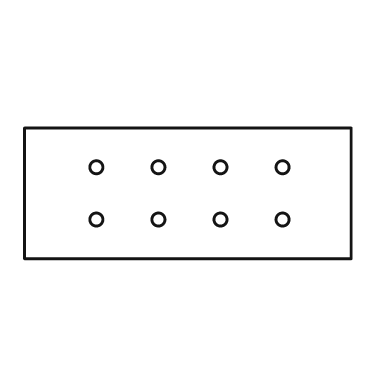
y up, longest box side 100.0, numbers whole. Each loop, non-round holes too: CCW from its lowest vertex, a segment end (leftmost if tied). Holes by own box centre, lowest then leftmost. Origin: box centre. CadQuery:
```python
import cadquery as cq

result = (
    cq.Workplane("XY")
    .moveTo(-50.0, -20.0)
    .lineTo(50.0, -20.0)
    .lineTo(50.0, 20.0)
    .lineTo(-50.0, 20.0)
    .close()
    .moveTo(-28.0, -8.0)
    .circle(2.0)
    .moveTo(-9.0, -8.0)
    .circle(2.0)
    .moveTo(10.0, -8.0)
    .circle(2.0)
    .moveTo(29.0, -8.0)
    .circle(2.0)
    .moveTo(-28.0, 8.0)
    .circle(2.0)
    .moveTo(-9.0, 8.0)
    .circle(2.0)
    .moveTo(10.0, 8.0)
    .circle(2.0)
    .moveTo(29.0, 8.0)
    .circle(2.0)
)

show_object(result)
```